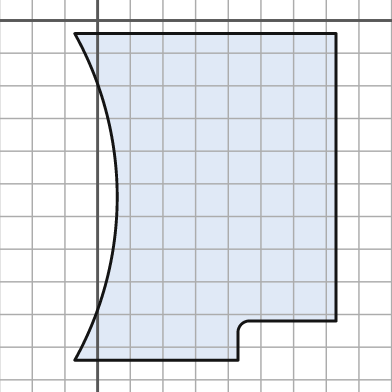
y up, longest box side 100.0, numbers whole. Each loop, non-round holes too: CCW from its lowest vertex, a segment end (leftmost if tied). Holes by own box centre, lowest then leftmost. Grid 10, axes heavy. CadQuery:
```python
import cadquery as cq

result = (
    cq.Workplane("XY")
    .moveTo(-7.0, -104.0)
    .lineTo(43.0, -104.0)
    .lineTo(43.0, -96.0)
    .threePointArc((44.0, -93.0), (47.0, -92.0))
    .lineTo(73.0, -92.0)
    .lineTo(73.0, -4.0)
    .lineTo(-7.0, -4.0)
    .threePointArc((6.0, -54.0), (-7.0, -104.0))
    .close()
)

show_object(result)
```